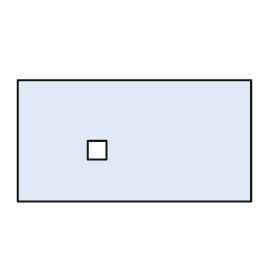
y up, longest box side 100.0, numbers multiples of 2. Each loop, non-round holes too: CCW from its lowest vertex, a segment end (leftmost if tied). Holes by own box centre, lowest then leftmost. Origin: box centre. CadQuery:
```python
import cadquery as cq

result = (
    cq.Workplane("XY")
    .moveTo(-50.0, -26.0)
    .lineTo(50.0, -26.0)
    .lineTo(50.0, 26.0)
    .lineTo(-50.0, 26.0)
    .close()
    .moveTo(-20.0, -8.0)
    .lineTo(-12.0, -8.0)
    .lineTo(-12.0, 0.0)
    .lineTo(-20.0, 0.0)
    .close()
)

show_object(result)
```